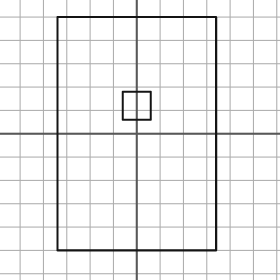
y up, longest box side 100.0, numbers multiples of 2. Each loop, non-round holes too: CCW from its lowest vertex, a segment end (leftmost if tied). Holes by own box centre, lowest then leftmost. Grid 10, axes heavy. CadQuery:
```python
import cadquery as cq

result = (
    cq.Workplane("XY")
    .moveTo(-34.0, -50.0)
    .lineTo(34.0, -50.0)
    .lineTo(34.0, 50.0)
    .lineTo(-34.0, 50.0)
    .close()
    .moveTo(-6.0, 6.0)
    .lineTo(6.0, 6.0)
    .lineTo(6.0, 18.0)
    .lineTo(-6.0, 18.0)
    .close()
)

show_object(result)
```